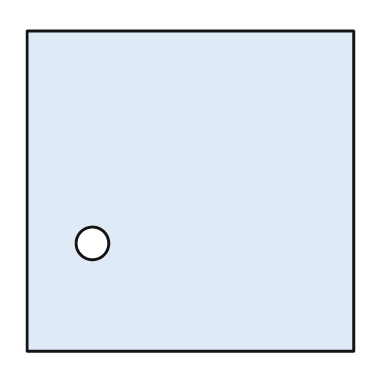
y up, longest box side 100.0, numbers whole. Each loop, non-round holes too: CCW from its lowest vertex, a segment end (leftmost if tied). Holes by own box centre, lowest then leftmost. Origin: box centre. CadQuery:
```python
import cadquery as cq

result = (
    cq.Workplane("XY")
    .moveTo(-50.0, -49.0)
    .lineTo(50.0, -49.0)
    .lineTo(50.0, 49.0)
    .lineTo(-50.0, 49.0)
    .close()
    .moveTo(-30.0, -16.0)
    .circle(5.0)
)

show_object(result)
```